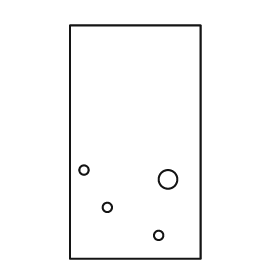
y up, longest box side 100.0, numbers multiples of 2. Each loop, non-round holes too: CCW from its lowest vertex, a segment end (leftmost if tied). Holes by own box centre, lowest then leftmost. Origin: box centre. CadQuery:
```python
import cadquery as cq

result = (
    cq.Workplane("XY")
    .moveTo(-28.0, -50.0)
    .lineTo(28.0, -50.0)
    .lineTo(28.0, 50.0)
    .lineTo(-28.0, 50.0)
    .close()
    .moveTo(10.0, -40.0)
    .circle(2.0)
    .moveTo(-12.0, -28.0)
    .circle(2.0)
    .moveTo(14.0, -16.0)
    .circle(4.0)
    .moveTo(-22.0, -12.0)
    .circle(2.0)
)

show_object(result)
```